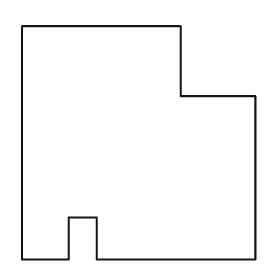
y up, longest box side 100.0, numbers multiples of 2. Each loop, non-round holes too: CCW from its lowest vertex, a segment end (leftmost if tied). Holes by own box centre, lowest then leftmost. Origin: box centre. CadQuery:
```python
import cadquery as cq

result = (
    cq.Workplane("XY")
    .moveTo(-50.0, -50.0)
    .lineTo(-30.0, -50.0)
    .lineTo(-30.0, -32.0)
    .lineTo(-18.0, -32.0)
    .lineTo(-18.0, -50.0)
    .lineTo(50.0, -50.0)
    .lineTo(50.0, 20.0)
    .lineTo(18.0, 20.0)
    .lineTo(18.0, 50.0)
    .lineTo(-50.0, 50.0)
    .close()
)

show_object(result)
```